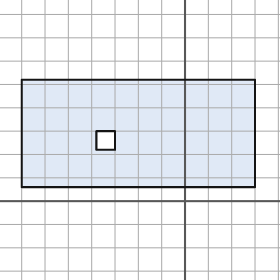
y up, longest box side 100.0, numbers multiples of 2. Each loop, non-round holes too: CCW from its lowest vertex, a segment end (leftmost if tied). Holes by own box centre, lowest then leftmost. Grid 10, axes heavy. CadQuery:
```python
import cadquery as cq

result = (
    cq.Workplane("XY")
    .moveTo(-70.0, 6.0)
    .lineTo(30.0, 6.0)
    .lineTo(30.0, 52.0)
    .lineTo(-70.0, 52.0)
    .close()
    .moveTo(-38.0, 22.0)
    .lineTo(-30.0, 22.0)
    .lineTo(-30.0, 30.0)
    .lineTo(-38.0, 30.0)
    .close()
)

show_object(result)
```